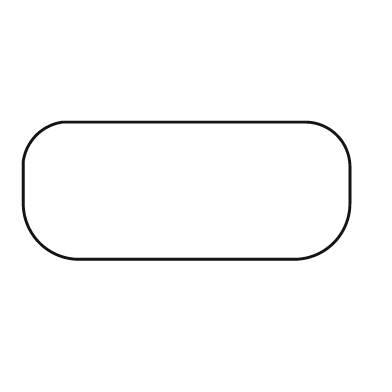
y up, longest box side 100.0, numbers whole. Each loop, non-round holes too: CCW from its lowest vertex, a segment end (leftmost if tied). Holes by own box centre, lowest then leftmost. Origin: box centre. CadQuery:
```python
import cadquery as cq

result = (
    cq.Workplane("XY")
    .moveTo(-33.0, -21.0)
    .lineTo(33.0, -21.0)
    .threePointArc((45.0, -16.0), (50.0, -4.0))
    .lineTo(50.0, 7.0)
    .threePointArc((46.0, 17.0), (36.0, 21.0))
    .lineTo(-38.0, 21.0)
    .threePointArc((-46.0, 17.0), (-50.0, 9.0))
    .lineTo(-50.0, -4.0)
    .threePointArc((-45.0, -16.0), (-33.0, -21.0))
    .close()
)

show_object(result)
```